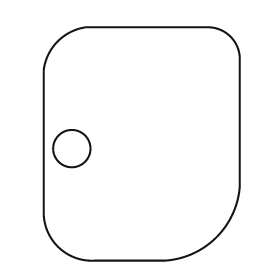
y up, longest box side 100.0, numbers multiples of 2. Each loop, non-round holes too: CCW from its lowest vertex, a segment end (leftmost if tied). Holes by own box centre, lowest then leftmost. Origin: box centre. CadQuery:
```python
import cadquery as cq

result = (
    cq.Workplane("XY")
    .moveTo(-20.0, -50.0)
    .lineTo(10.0, -50.0)
    .threePointArc((32.0, -40.0), (42.0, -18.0))
    .lineTo(42.0, 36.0)
    .threePointArc((38.0, 46.0), (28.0, 50.0))
    .lineTo(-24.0, 50.0)
    .threePointArc((-36.0, 44.0), (-42.0, 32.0))
    .lineTo(-42.0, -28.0)
    .threePointArc((-36.0, -44.0), (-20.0, -50.0))
    .close()
    .moveTo(-30.0, -2.0)
    .circle(8.0)
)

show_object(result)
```